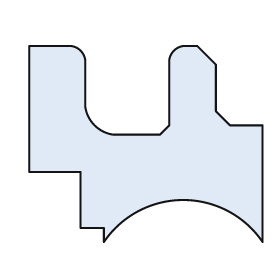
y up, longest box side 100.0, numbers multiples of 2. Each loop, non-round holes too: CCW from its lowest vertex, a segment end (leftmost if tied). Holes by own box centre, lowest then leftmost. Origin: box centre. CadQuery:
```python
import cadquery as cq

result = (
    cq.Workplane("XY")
    .moveTo(-18.0, -42.0)
    .threePointArc((16.0, -24.0), (50.0, -42.0))
    .lineTo(50.0, 8.0)
    .lineTo(36.0, 8.0)
    .lineTo(30.0, 14.0)
    .lineTo(30.0, 34.0)
    .lineTo(22.0, 42.0)
    .lineTo(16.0, 42.0)
    .threePointArc((12.0, 40.0), (10.0, 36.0))
    .lineTo(10.0, 8.0)
    .lineTo(6.0, 4.0)
    .lineTo(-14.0, 4.0)
    .threePointArc((-22.0, 8.0), (-26.0, 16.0))
    .lineTo(-26.0, 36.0)
    .threePointArc((-28.0, 40.0), (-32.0, 42.0))
    .lineTo(-50.0, 42.0)
    .lineTo(-50.0, -12.0)
    .lineTo(-28.0, -12.0)
    .lineTo(-28.0, -36.0)
    .lineTo(-18.0, -36.0)
    .close()
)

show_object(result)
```